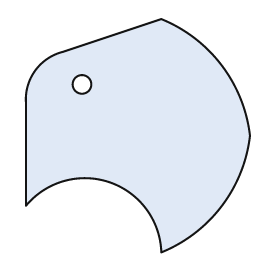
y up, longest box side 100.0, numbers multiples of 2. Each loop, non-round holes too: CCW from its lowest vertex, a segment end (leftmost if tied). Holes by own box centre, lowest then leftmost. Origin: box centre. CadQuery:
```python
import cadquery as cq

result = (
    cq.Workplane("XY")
    .moveTo(10.0, -50.0)
    .threePointArc((36.0, -30.0), (48.0, 0.0))
    .threePointArc((36.0, 30.0), (10.0, 50.0))
    .lineTo(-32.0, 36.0)
    .threePointArc((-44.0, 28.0), (-48.0, 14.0))
    .lineTo(-48.0, -30.0)
    .threePointArc((-12.0, -20.0), (10.0, -50.0))
    .close()
    .moveTo(-24.0, 22.0)
    .circle(4.0)
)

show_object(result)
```